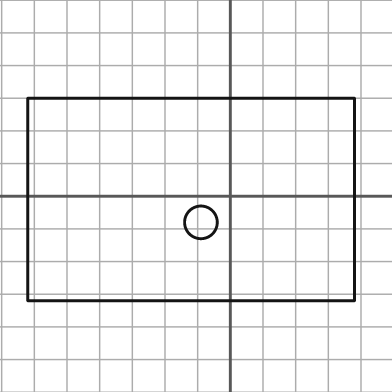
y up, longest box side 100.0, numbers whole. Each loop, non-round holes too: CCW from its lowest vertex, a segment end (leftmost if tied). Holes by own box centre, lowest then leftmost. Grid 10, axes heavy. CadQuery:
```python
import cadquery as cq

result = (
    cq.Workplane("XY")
    .moveTo(-62.0, -32.0)
    .lineTo(38.0, -32.0)
    .lineTo(38.0, 30.0)
    .lineTo(-62.0, 30.0)
    .close()
    .moveTo(-9.0, -8.0)
    .circle(5.0)
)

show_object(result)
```